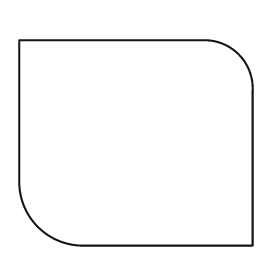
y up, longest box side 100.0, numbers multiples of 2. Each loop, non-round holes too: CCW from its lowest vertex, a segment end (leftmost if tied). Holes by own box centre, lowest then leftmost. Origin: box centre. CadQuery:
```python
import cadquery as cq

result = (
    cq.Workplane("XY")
    .moveTo(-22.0, -44.0)
    .lineTo(50.0, -44.0)
    .lineTo(50.0, 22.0)
    .threePointArc((44.0, 38.0), (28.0, 44.0))
    .lineTo(-50.0, 44.0)
    .lineTo(-50.0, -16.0)
    .threePointArc((-42.0, -36.0), (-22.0, -44.0))
    .close()
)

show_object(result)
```